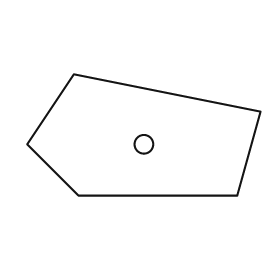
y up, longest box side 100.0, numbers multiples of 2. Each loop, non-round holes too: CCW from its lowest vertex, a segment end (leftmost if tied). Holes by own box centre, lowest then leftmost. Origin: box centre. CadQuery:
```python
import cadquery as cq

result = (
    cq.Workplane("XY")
    .moveTo(-28.0, -26.0)
    .lineTo(40.0, -26.0)
    .lineTo(50.0, 10.0)
    .lineTo(-30.0, 26.0)
    .lineTo(-50.0, -4.0)
    .close()
    .moveTo(0.0, -4.0)
    .circle(4.0)
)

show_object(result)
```